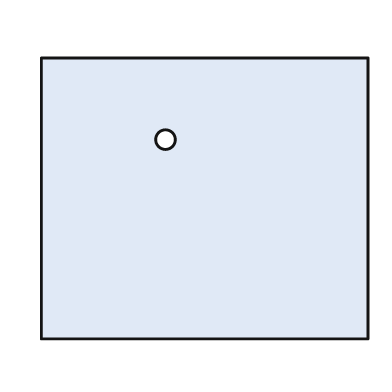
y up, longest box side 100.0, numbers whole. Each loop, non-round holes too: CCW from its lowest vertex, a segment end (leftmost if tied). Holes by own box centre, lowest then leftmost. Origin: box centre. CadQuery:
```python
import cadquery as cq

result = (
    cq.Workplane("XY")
    .moveTo(-50.0, -43.0)
    .lineTo(50.0, -43.0)
    .lineTo(50.0, 43.0)
    .lineTo(-50.0, 43.0)
    .close()
    .moveTo(-12.0, 18.0)
    .circle(3.0)
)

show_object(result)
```